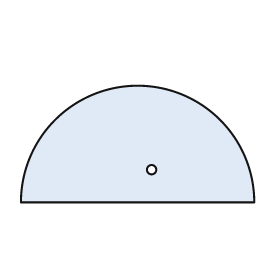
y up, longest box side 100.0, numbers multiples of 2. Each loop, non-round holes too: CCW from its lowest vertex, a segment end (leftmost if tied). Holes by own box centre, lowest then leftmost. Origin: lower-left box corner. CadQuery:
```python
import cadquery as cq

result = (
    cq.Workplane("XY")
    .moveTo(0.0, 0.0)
    .lineTo(100.0, 0.0)
    .threePointArc((50.0, 50.0), (0.0, 0.0))
    .close()
    .moveTo(56.0, 14.0)
    .circle(2.0)
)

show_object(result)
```